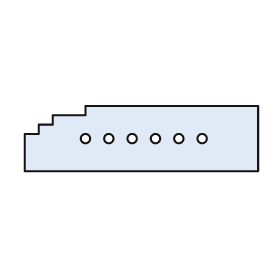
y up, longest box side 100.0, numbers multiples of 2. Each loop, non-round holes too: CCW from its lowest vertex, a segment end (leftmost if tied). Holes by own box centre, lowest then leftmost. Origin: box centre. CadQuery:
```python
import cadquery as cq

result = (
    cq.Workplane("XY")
    .moveTo(-50.0, -14.0)
    .lineTo(50.0, -14.0)
    .lineTo(50.0, 14.0)
    .lineTo(-24.0, 14.0)
    .lineTo(-24.0, 10.0)
    .lineTo(-38.0, 10.0)
    .lineTo(-38.0, 6.0)
    .lineTo(-44.0, 6.0)
    .lineTo(-44.0, 2.0)
    .lineTo(-50.0, 2.0)
    .close()
    .moveTo(-24.0, 0.0)
    .circle(2.0)
    .moveTo(-14.0, 0.0)
    .circle(2.0)
    .moveTo(-4.0, 0.0)
    .circle(2.0)
    .moveTo(6.0, 0.0)
    .circle(2.0)
    .moveTo(16.0, 0.0)
    .circle(2.0)
    .moveTo(26.0, 0.0)
    .circle(2.0)
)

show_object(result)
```